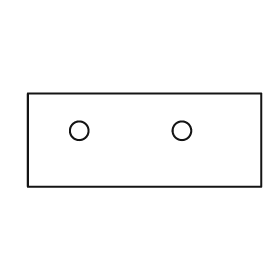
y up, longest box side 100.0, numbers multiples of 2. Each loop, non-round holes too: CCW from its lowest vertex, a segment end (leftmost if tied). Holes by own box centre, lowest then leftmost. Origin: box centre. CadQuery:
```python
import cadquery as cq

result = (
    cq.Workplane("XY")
    .moveTo(-50.0, -20.0)
    .lineTo(50.0, -20.0)
    .lineTo(50.0, 20.0)
    .lineTo(-50.0, 20.0)
    .close()
    .moveTo(-28.0, 4.0)
    .circle(4.0)
    .moveTo(16.0, 4.0)
    .circle(4.0)
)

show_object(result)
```